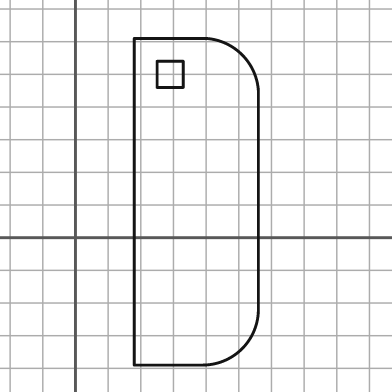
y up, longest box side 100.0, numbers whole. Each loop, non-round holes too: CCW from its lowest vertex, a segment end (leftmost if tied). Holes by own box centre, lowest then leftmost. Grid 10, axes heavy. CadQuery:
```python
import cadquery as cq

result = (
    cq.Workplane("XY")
    .moveTo(18.0, -39.0)
    .lineTo(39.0, -39.0)
    .threePointArc((51.0, -34.0), (56.0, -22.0))
    .lineTo(56.0, 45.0)
    .threePointArc((51.0, 56.0), (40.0, 61.0))
    .lineTo(18.0, 61.0)
    .close()
    .moveTo(25.0, 46.0)
    .lineTo(33.0, 46.0)
    .lineTo(33.0, 54.0)
    .lineTo(25.0, 54.0)
    .close()
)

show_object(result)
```